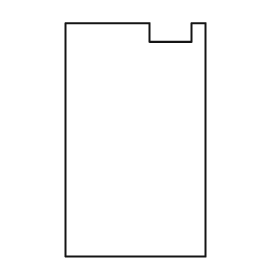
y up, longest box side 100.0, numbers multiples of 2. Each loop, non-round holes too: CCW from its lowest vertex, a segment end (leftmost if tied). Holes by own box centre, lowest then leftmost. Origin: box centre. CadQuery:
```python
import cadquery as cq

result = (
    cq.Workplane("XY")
    .moveTo(-30.0, -50.0)
    .lineTo(30.0, -50.0)
    .lineTo(30.0, 50.0)
    .lineTo(24.0, 50.0)
    .lineTo(24.0, 42.0)
    .lineTo(6.0, 42.0)
    .lineTo(6.0, 50.0)
    .lineTo(-30.0, 50.0)
    .close()
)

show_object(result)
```